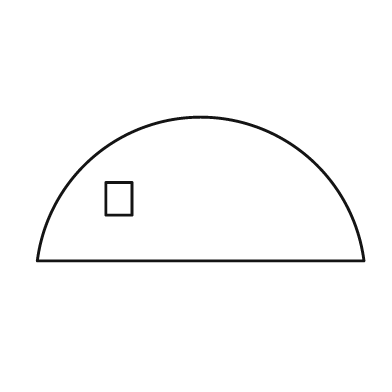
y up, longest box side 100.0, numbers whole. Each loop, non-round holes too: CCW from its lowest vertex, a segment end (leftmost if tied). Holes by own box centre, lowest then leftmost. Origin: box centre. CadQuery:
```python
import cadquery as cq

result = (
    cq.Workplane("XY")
    .moveTo(-50.0, -22.0)
    .lineTo(50.0, -22.0)
    .threePointArc((0.0, 22.0), (-50.0, -22.0))
    .close()
    .moveTo(-29.0, -8.0)
    .lineTo(-21.0, -8.0)
    .lineTo(-21.0, 2.0)
    .lineTo(-29.0, 2.0)
    .close()
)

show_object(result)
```